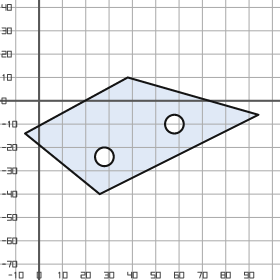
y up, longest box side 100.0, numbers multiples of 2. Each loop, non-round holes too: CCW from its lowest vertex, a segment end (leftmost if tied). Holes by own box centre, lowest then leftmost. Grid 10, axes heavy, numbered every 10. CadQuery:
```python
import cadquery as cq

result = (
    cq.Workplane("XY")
    .moveTo(26.0, -40.0)
    .lineTo(94.0, -6.0)
    .lineTo(38.0, 10.0)
    .lineTo(-6.0, -14.0)
    .close()
    .moveTo(28.0, -24.0)
    .circle(4.0)
    .moveTo(58.0, -10.0)
    .circle(4.0)
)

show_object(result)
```